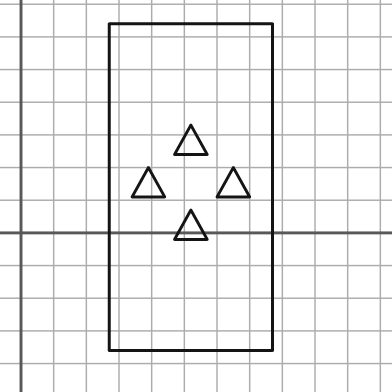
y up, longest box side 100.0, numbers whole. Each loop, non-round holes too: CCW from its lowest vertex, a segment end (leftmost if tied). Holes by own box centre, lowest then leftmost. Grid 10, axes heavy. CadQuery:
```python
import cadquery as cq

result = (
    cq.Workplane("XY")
    .moveTo(27.0, -36.0)
    .lineTo(77.0, -36.0)
    .lineTo(77.0, 64.0)
    .lineTo(27.0, 64.0)
    .close()
    .moveTo(47.0, -2.0)
    .lineTo(57.0, -2.0)
    .lineTo(52.0, 7.0)
    .close()
    .moveTo(34.0, 11.0)
    .lineTo(44.0, 11.0)
    .lineTo(39.0, 20.0)
    .close()
    .moveTo(60.0, 11.0)
    .lineTo(70.0, 11.0)
    .lineTo(65.0, 20.0)
    .close()
    .moveTo(47.0, 24.0)
    .lineTo(57.0, 24.0)
    .lineTo(52.0, 33.0)
    .close()
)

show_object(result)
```